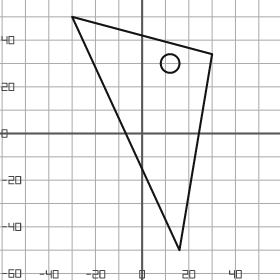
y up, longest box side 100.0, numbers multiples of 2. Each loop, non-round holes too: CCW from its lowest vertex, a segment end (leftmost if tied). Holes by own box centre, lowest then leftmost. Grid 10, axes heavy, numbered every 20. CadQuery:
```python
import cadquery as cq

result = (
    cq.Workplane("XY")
    .moveTo(16.0, -50.0)
    .lineTo(30.0, 34.0)
    .lineTo(-30.0, 50.0)
    .close()
    .moveTo(12.0, 30.0)
    .circle(4.0)
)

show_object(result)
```